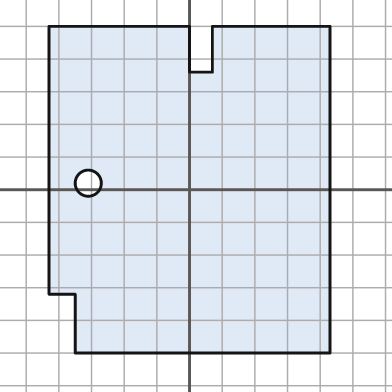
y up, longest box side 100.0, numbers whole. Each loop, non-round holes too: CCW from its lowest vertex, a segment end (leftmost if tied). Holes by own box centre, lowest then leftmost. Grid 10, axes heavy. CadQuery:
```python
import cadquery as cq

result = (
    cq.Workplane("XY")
    .moveTo(-35.0, -50.0)
    .lineTo(43.0, -50.0)
    .lineTo(43.0, 50.0)
    .lineTo(7.0, 50.0)
    .lineTo(7.0, 36.0)
    .lineTo(0.0, 36.0)
    .lineTo(0.0, 50.0)
    .lineTo(-43.0, 50.0)
    .lineTo(-43.0, -32.0)
    .lineTo(-35.0, -32.0)
    .close()
    .moveTo(-31.0, 2.0)
    .circle(4.0)
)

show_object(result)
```